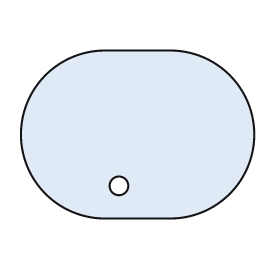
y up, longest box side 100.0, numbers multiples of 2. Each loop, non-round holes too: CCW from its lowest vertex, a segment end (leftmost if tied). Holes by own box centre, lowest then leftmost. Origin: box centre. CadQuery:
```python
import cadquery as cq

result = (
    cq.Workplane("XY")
    .moveTo(-14.0, -36.0)
    .lineTo(14.0, -36.0)
    .threePointArc((50.0, 0.0), (14.0, 36.0))
    .lineTo(-14.0, 36.0)
    .threePointArc((-50.0, 0.0), (-14.0, -36.0))
    .close()
    .moveTo(-8.0, -22.0)
    .circle(4.0)
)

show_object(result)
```